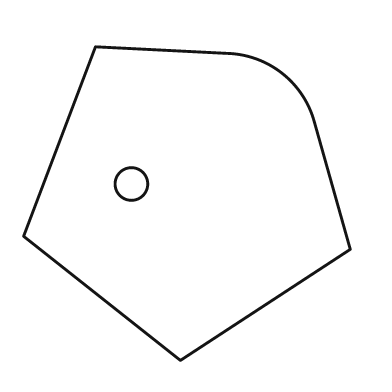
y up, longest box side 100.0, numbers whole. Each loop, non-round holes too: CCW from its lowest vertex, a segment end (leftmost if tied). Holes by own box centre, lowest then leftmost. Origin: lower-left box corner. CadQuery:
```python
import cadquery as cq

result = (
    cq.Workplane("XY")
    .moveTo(48.0, 0.0)
    .lineTo(100.0, 34.0)
    .lineTo(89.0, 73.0)
    .threePointArc((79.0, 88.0), (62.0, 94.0))
    .lineTo(22.0, 96.0)
    .lineTo(0.0, 38.0)
    .close()
    .moveTo(33.0, 54.0)
    .circle(5.0)
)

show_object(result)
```